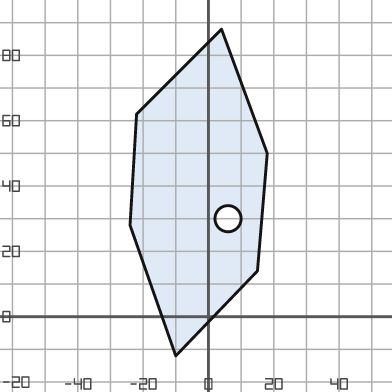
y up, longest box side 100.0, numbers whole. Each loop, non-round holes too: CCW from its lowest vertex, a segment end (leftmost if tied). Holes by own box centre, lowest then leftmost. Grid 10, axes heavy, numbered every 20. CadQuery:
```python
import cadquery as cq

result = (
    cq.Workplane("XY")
    .moveTo(-10.0, -12.0)
    .lineTo(15.0, 14.0)
    .lineTo(18.0, 50.0)
    .lineTo(4.0, 88.0)
    .lineTo(-22.0, 62.0)
    .lineTo(-24.0, 28.0)
    .close()
    .moveTo(6.0, 30.0)
    .circle(4.0)
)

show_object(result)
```